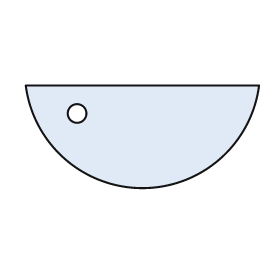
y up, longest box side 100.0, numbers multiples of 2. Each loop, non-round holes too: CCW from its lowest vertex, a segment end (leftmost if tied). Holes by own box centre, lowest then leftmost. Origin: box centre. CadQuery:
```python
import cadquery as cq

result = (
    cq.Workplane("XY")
    .moveTo(-50.0, 22.0)
    .threePointArc((0.0, -22.0), (50.0, 22.0))
    .close()
    .moveTo(-28.0, 10.0)
    .circle(4.0)
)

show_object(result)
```